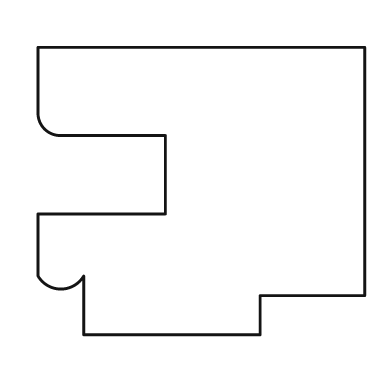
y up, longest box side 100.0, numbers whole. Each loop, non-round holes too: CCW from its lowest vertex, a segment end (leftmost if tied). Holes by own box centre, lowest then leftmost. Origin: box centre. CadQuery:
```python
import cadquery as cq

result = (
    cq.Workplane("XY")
    .moveTo(-36.0, -44.0)
    .lineTo(18.0, -44.0)
    .lineTo(18.0, -32.0)
    .lineTo(50.0, -32.0)
    .lineTo(50.0, 44.0)
    .lineTo(-50.0, 44.0)
    .lineTo(-50.0, 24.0)
    .threePointArc((-48.0, 19.0), (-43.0, 17.0))
    .lineTo(-11.0, 17.0)
    .lineTo(-11.0, -7.0)
    .lineTo(-50.0, -7.0)
    .lineTo(-50.0, -26.0)
    .threePointArc((-43.0, -30.0), (-36.0, -26.0))
    .close()
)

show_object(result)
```